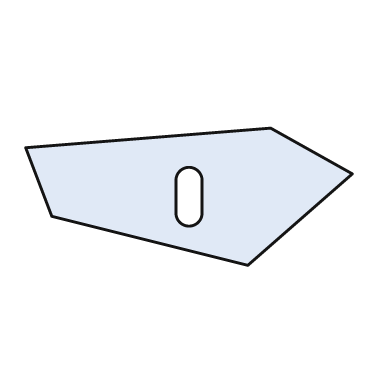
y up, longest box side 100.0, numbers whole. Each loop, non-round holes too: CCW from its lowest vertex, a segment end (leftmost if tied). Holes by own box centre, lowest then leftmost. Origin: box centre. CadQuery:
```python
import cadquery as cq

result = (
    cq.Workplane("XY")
    .moveTo(18.0, -21.0)
    .lineTo(50.0, 7.0)
    .lineTo(25.0, 21.0)
    .lineTo(-50.0, 15.0)
    .lineTo(-42.0, -6.0)
    .close()
    .moveTo(-4.0, -5.0)
    .threePointArc((0.0, -9.0), (4.0, -5.0))
    .lineTo(4.0, 5.0)
    .threePointArc((0.0, 9.0), (-4.0, 5.0))
    .close()
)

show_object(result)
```